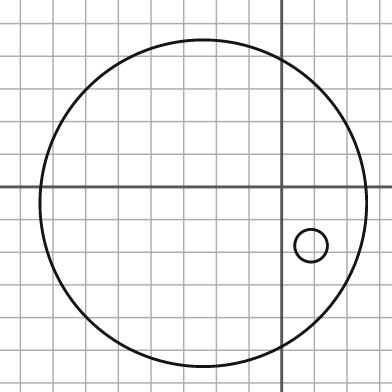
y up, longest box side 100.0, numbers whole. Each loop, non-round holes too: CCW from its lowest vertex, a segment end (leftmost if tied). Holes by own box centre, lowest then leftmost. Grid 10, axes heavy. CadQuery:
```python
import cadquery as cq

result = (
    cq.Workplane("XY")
    .moveTo(-24.0, -5.0)
    .circle(50.0)
    .moveTo(9.0, -18.0)
    .circle(5.0)
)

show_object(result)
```